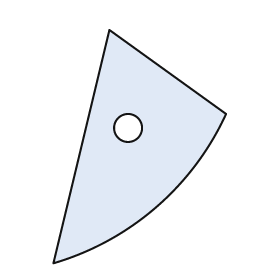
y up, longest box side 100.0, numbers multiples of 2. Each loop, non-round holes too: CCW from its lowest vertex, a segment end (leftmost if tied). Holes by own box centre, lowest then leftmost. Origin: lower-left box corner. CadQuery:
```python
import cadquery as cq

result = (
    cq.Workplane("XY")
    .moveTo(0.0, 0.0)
    .threePointArc((44.0, 24.0), (74.0, 64.0))
    .lineTo(24.0, 100.0)
    .close()
    .moveTo(32.0, 58.0)
    .circle(6.0)
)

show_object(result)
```